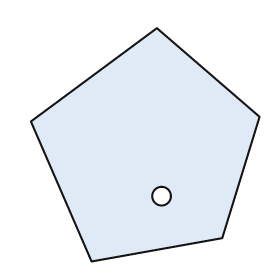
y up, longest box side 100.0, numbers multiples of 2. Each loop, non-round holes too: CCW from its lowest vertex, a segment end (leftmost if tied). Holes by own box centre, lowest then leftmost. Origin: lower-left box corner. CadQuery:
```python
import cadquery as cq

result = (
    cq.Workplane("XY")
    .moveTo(26.0, 0.0)
    .lineTo(82.0, 10.0)
    .lineTo(98.0, 62.0)
    .lineTo(54.0, 100.0)
    .lineTo(0.0, 60.0)
    .close()
    .moveTo(56.0, 28.0)
    .circle(4.0)
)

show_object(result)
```